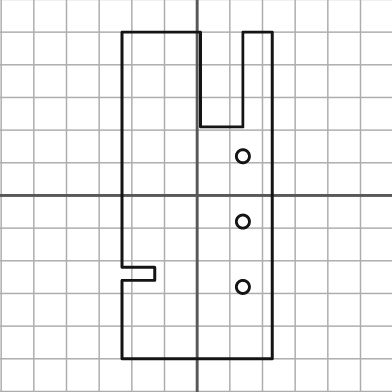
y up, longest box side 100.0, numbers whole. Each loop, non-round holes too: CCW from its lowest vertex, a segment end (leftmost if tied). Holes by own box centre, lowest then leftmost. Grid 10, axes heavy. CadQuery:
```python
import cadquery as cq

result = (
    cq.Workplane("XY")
    .moveTo(-23.0, -50.0)
    .lineTo(23.0, -50.0)
    .lineTo(23.0, 50.0)
    .lineTo(14.0, 50.0)
    .lineTo(14.0, 21.0)
    .lineTo(1.0, 21.0)
    .lineTo(1.0, 50.0)
    .lineTo(-23.0, 50.0)
    .lineTo(-23.0, -22.0)
    .lineTo(-13.0, -22.0)
    .lineTo(-13.0, -26.0)
    .lineTo(-23.0, -26.0)
    .close()
    .moveTo(14.0, -28.0)
    .circle(2.0)
    .moveTo(14.0, -8.0)
    .circle(2.0)
    .moveTo(14.0, 12.0)
    .circle(2.0)
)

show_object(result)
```